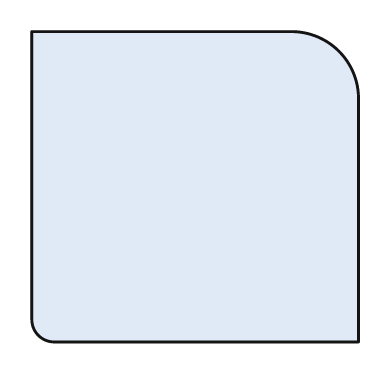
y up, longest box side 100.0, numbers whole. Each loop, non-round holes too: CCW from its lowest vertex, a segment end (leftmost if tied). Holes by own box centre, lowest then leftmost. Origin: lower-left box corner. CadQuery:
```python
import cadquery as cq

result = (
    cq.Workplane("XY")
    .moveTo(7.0, 0.0)
    .lineTo(100.0, 0.0)
    .lineTo(100.0, 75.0)
    .threePointArc((94.0, 89.0), (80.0, 95.0))
    .lineTo(0.0, 95.0)
    .lineTo(0.0, 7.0)
    .threePointArc((2.0, 2.0), (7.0, 0.0))
    .close()
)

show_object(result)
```